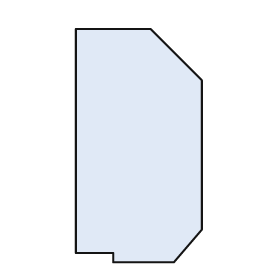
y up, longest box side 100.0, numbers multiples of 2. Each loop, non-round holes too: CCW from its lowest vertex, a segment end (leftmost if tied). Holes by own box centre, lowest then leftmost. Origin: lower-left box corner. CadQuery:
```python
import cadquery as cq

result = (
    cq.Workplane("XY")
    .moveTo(16.0, 0.0)
    .lineTo(42.0, 0.0)
    .lineTo(54.0, 14.0)
    .lineTo(54.0, 78.0)
    .lineTo(32.0, 100.0)
    .lineTo(0.0, 100.0)
    .lineTo(0.0, 4.0)
    .lineTo(16.0, 4.0)
    .close()
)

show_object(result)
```